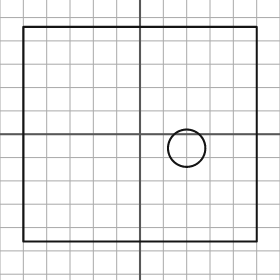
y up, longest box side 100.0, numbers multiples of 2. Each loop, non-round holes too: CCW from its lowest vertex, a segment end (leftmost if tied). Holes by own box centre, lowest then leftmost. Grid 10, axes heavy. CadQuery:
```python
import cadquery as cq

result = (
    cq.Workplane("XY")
    .moveTo(-50.0, -46.0)
    .lineTo(50.0, -46.0)
    .lineTo(50.0, 46.0)
    .lineTo(-50.0, 46.0)
    .close()
    .moveTo(20.0, -6.0)
    .circle(8.0)
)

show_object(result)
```